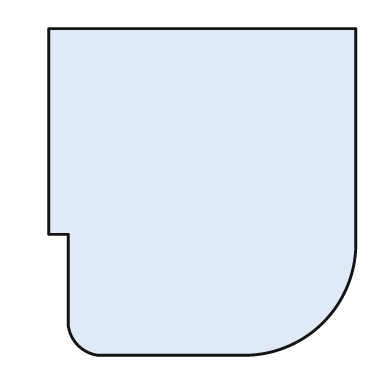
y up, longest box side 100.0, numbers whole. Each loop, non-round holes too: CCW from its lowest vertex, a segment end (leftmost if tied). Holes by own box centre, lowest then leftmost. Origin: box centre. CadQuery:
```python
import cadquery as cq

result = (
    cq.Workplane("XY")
    .moveTo(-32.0, -50.0)
    .lineTo(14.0, -50.0)
    .threePointArc((37.0, -40.0), (47.0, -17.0))
    .lineTo(47.0, 50.0)
    .lineTo(-47.0, 50.0)
    .lineTo(-47.0, -13.0)
    .lineTo(-41.0, -13.0)
    .lineTo(-41.0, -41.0)
    .threePointArc((-38.0, -47.0), (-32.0, -50.0))
    .close()
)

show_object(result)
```